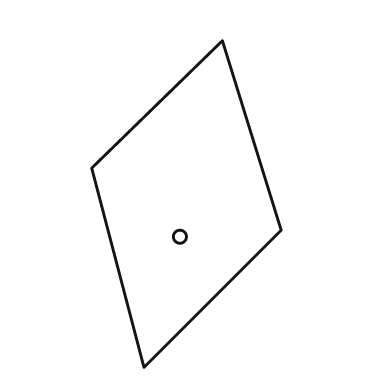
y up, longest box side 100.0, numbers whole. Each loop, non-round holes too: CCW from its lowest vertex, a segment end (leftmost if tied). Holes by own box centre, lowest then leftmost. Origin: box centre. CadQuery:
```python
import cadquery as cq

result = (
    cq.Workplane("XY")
    .moveTo(-13.0, -50.0)
    .lineTo(29.0, -8.0)
    .lineTo(11.0, 50.0)
    .lineTo(-29.0, 11.0)
    .close()
    .moveTo(-2.0, -10.0)
    .circle(2.0)
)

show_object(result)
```